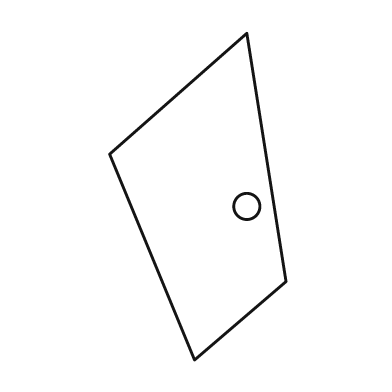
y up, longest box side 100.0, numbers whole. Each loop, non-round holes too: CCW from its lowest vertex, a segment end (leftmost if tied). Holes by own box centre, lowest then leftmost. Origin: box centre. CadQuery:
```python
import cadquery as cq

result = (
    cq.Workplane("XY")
    .moveTo(-1.0, -50.0)
    .lineTo(27.0, -26.0)
    .lineTo(15.0, 50.0)
    .lineTo(-27.0, 13.0)
    .close()
    .moveTo(15.0, -3.0)
    .circle(4.0)
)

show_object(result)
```